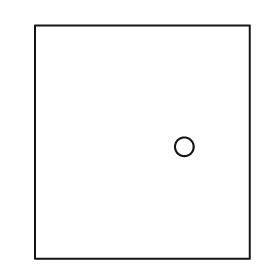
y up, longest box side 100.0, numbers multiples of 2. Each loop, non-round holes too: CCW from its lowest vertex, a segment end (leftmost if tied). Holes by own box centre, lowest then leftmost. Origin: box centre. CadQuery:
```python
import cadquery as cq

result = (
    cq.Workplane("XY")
    .moveTo(-46.0, -50.0)
    .lineTo(46.0, -50.0)
    .lineTo(46.0, 50.0)
    .lineTo(-46.0, 50.0)
    .close()
    .moveTo(18.0, -2.0)
    .circle(4.0)
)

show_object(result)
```